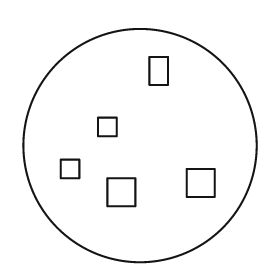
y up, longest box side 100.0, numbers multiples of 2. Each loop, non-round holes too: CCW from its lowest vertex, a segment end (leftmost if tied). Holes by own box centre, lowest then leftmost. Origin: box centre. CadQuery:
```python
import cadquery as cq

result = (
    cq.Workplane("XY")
    .moveTo(0.0, 0.0)
    .circle(50.0)
    .moveTo(-14.0, -26.0)
    .lineTo(-2.0, -26.0)
    .lineTo(-2.0, -14.0)
    .lineTo(-14.0, -14.0)
    .close()
    .moveTo(20.0, -22.0)
    .lineTo(32.0, -22.0)
    .lineTo(32.0, -10.0)
    .lineTo(20.0, -10.0)
    .close()
    .moveTo(-34.0, -14.0)
    .lineTo(-26.0, -14.0)
    .lineTo(-26.0, -6.0)
    .lineTo(-34.0, -6.0)
    .close()
    .moveTo(-18.0, 4.0)
    .lineTo(-10.0, 4.0)
    .lineTo(-10.0, 12.0)
    .lineTo(-18.0, 12.0)
    .close()
    .moveTo(4.0, 26.0)
    .lineTo(12.0, 26.0)
    .lineTo(12.0, 38.0)
    .lineTo(4.0, 38.0)
    .close()
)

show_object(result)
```